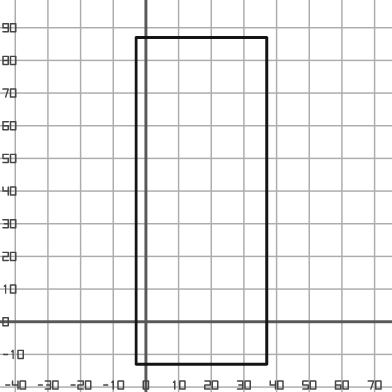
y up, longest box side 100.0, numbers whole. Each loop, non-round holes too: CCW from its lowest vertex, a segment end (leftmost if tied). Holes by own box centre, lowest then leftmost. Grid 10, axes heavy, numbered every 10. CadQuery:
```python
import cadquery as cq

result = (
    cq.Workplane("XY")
    .moveTo(-3.0, -13.0)
    .lineTo(37.0, -13.0)
    .lineTo(37.0, 87.0)
    .lineTo(-3.0, 87.0)
    .close()
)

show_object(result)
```